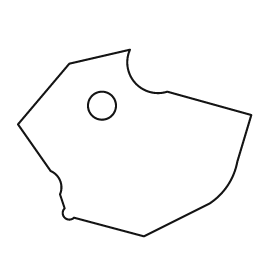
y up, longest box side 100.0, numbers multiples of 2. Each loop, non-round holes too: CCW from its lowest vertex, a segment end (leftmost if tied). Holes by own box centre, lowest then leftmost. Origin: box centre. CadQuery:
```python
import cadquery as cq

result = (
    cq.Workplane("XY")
    .moveTo(4.0, -40.0)
    .lineTo(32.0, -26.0)
    .threePointArc((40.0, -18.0), (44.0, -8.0))
    .lineTo(50.0, 12.0)
    .lineTo(14.0, 22.0)
    .threePointArc((0.0, 26.0), (-2.0, 40.0))
    .lineTo(-28.0, 34.0)
    .lineTo(-50.0, 8.0)
    .lineTo(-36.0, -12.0)
    .threePointArc((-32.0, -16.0), (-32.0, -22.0))
    .lineTo(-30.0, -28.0)
    .threePointArc((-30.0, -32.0), (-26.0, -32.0))
    .close()
    .moveTo(-14.0, 16.0)
    .circle(6.0)
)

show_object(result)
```